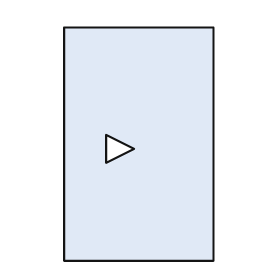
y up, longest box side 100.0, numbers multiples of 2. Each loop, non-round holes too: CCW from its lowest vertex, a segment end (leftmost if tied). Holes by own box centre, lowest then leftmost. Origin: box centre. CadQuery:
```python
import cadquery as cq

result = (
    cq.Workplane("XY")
    .moveTo(-32.0, -50.0)
    .lineTo(32.0, -50.0)
    .lineTo(32.0, 50.0)
    .lineTo(-32.0, 50.0)
    .close()
    .moveTo(-14.0, -8.0)
    .lineTo(-2.0, -2.0)
    .lineTo(-14.0, 4.0)
    .close()
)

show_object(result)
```